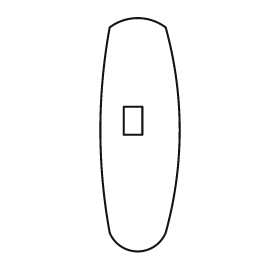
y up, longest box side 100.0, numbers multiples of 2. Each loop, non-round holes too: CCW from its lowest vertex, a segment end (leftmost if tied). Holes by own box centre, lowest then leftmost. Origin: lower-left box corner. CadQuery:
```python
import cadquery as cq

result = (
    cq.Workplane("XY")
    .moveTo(4.0, 8.0)
    .threePointArc((16.0, 0.0), (28.0, 8.0))
    .threePointArc((34.0, 52.0), (28.0, 96.0))
    .threePointArc((16.0, 100.0), (4.0, 96.0))
    .threePointArc((0.0, 52.0), (4.0, 8.0))
    .close()
    .moveTo(10.0, 50.0)
    .lineTo(18.0, 50.0)
    .lineTo(18.0, 62.0)
    .lineTo(10.0, 62.0)
    .close()
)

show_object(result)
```